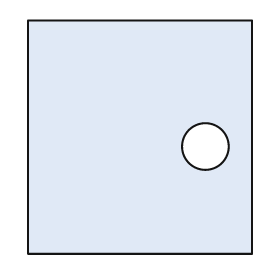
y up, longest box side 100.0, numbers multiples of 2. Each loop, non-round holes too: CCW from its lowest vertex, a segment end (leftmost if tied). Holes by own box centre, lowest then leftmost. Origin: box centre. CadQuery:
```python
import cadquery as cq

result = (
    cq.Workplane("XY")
    .moveTo(-48.0, -50.0)
    .lineTo(48.0, -50.0)
    .lineTo(48.0, 50.0)
    .lineTo(-48.0, 50.0)
    .close()
    .moveTo(28.0, -4.0)
    .circle(10.0)
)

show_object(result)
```